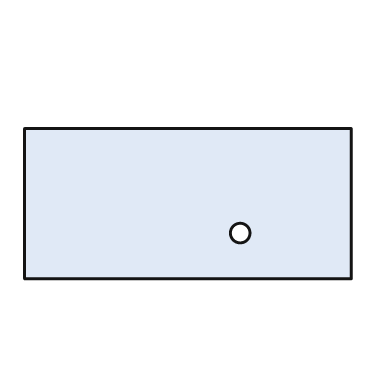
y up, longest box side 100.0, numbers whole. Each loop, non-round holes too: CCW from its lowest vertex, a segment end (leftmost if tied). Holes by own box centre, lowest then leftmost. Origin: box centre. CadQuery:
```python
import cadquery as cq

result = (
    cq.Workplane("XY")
    .moveTo(-50.0, -23.0)
    .lineTo(50.0, -23.0)
    .lineTo(50.0, 23.0)
    .lineTo(-50.0, 23.0)
    .close()
    .moveTo(16.0, -9.0)
    .circle(3.0)
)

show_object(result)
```